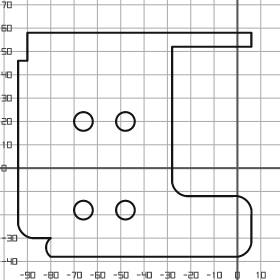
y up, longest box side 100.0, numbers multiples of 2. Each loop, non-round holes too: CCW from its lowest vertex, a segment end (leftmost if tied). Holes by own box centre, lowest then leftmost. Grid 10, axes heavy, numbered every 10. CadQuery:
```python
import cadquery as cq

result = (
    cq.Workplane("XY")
    .moveTo(-80.0, -38.0)
    .lineTo(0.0, -38.0)
    .threePointArc((4.0, -36.0), (6.0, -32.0))
    .lineTo(6.0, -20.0)
    .threePointArc((4.0, -14.0), (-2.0, -12.0))
    .lineTo(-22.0, -12.0)
    .threePointArc((-26.0, -10.0), (-28.0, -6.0))
    .lineTo(-28.0, 52.0)
    .lineTo(6.0, 52.0)
    .lineTo(6.0, 58.0)
    .lineTo(-90.0, 58.0)
    .lineTo(-90.0, 46.0)
    .lineTo(-94.0, 46.0)
    .lineTo(-94.0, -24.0)
    .threePointArc((-92.0, -28.0), (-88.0, -30.0))
    .lineTo(-80.0, -30.0)
    .threePointArc((-82.0, -34.0), (-80.0, -38.0))
    .close()
    .moveTo(-66.0, -18.0)
    .circle(4.0)
    .moveTo(-48.0, -18.0)
    .circle(4.0)
    .moveTo(-66.0, 20.0)
    .circle(4.0)
    .moveTo(-48.0, 20.0)
    .circle(4.0)
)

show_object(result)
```